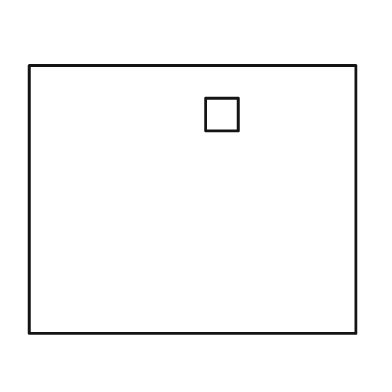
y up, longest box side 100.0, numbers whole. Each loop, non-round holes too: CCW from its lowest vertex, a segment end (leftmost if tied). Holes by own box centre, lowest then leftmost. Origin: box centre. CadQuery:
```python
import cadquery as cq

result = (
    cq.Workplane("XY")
    .moveTo(-50.0, -41.0)
    .lineTo(50.0, -41.0)
    .lineTo(50.0, 41.0)
    .lineTo(-50.0, 41.0)
    .close()
    .moveTo(4.0, 21.0)
    .lineTo(14.0, 21.0)
    .lineTo(14.0, 31.0)
    .lineTo(4.0, 31.0)
    .close()
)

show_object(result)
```